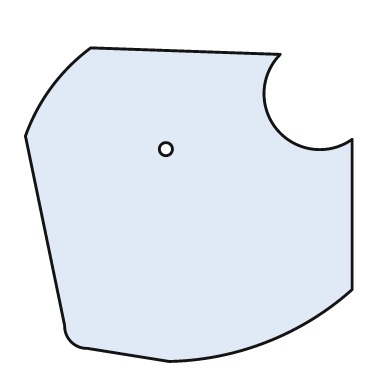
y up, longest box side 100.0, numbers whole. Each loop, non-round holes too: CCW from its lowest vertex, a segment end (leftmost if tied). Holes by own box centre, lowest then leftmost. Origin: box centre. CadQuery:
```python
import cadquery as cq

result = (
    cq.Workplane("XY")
    .moveTo(-6.0, -48.0)
    .threePointArc((24.0, -42.0), (50.0, -26.0))
    .lineTo(50.0, 20.0)
    .threePointArc((27.0, 23.0), (28.0, 46.0))
    .lineTo(-30.0, 48.0)
    .threePointArc((-42.0, 36.0), (-50.0, 21.0))
    .lineTo(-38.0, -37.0)
    .threePointArc((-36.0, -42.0), (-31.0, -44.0))
    .close()
    .moveTo(-7.0, 17.0)
    .circle(2.0)
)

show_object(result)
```